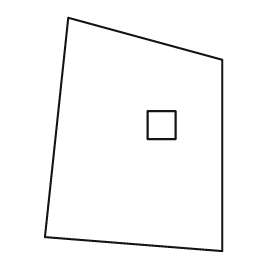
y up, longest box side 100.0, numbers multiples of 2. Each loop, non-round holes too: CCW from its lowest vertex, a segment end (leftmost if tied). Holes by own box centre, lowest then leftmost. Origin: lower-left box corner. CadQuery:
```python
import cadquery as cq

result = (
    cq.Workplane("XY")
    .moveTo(76.0, 0.0)
    .lineTo(76.0, 82.0)
    .lineTo(10.0, 100.0)
    .lineTo(0.0, 6.0)
    .close()
    .moveTo(44.0, 48.0)
    .lineTo(56.0, 48.0)
    .lineTo(56.0, 60.0)
    .lineTo(44.0, 60.0)
    .close()
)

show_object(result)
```